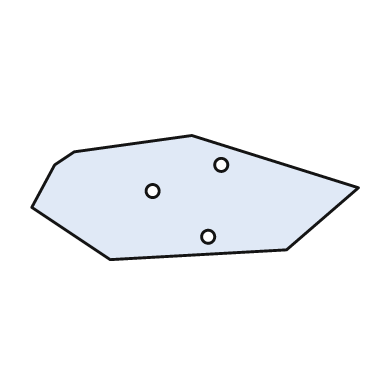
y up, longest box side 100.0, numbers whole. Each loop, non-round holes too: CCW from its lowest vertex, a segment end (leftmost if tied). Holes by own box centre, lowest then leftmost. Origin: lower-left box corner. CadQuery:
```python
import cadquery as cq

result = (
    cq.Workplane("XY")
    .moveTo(24.0, 0.0)
    .lineTo(78.0, 3.0)
    .lineTo(100.0, 22.0)
    .lineTo(49.0, 38.0)
    .lineTo(13.0, 33.0)
    .lineTo(7.0, 29.0)
    .lineTo(0.0, 16.0)
    .close()
    .moveTo(54.0, 7.0)
    .circle(2.0)
    .moveTo(37.0, 21.0)
    .circle(2.0)
    .moveTo(58.0, 29.0)
    .circle(2.0)
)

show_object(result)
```